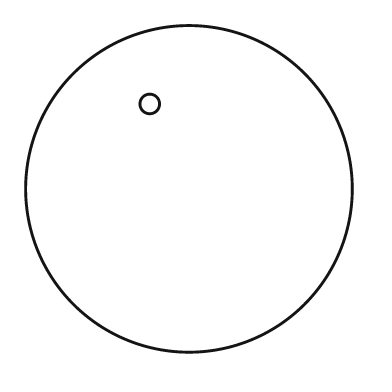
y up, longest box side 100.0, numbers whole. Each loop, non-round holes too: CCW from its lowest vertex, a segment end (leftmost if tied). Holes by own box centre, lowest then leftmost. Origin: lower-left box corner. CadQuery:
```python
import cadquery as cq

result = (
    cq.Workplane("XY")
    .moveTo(50.0, 50.0)
    .circle(50.0)
    .moveTo(38.0, 76.0)
    .circle(3.0)
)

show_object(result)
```